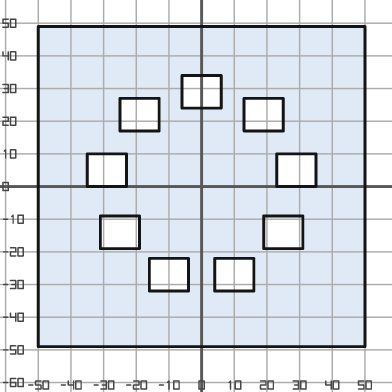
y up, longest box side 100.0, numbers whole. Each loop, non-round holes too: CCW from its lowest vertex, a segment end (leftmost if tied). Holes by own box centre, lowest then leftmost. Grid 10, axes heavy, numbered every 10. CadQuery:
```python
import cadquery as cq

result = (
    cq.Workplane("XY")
    .moveTo(-50.0, -49.0)
    .lineTo(50.0, -49.0)
    .lineTo(50.0, 49.0)
    .lineTo(-50.0, 49.0)
    .close()
    .moveTo(-16.0, -32.0)
    .lineTo(-4.0, -32.0)
    .lineTo(-4.0, -22.0)
    .lineTo(-16.0, -22.0)
    .close()
    .moveTo(4.0, -32.0)
    .lineTo(16.0, -32.0)
    .lineTo(16.0, -22.0)
    .lineTo(4.0, -22.0)
    .close()
    .moveTo(-31.0, -19.0)
    .lineTo(-19.0, -19.0)
    .lineTo(-19.0, -9.0)
    .lineTo(-31.0, -9.0)
    .close()
    .moveTo(19.0, -19.0)
    .lineTo(31.0, -19.0)
    .lineTo(31.0, -9.0)
    .lineTo(19.0, -9.0)
    .close()
    .moveTo(-35.0, 0.0)
    .lineTo(-23.0, 0.0)
    .lineTo(-23.0, 10.0)
    .lineTo(-35.0, 10.0)
    .close()
    .moveTo(23.0, 0.0)
    .lineTo(35.0, 0.0)
    .lineTo(35.0, 10.0)
    .lineTo(23.0, 10.0)
    .close()
    .moveTo(-25.0, 17.0)
    .lineTo(-13.0, 17.0)
    .lineTo(-13.0, 27.0)
    .lineTo(-25.0, 27.0)
    .close()
    .moveTo(13.0, 17.0)
    .lineTo(25.0, 17.0)
    .lineTo(25.0, 27.0)
    .lineTo(13.0, 27.0)
    .close()
    .moveTo(-6.0, 24.0)
    .lineTo(6.0, 24.0)
    .lineTo(6.0, 34.0)
    .lineTo(-6.0, 34.0)
    .close()
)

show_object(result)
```